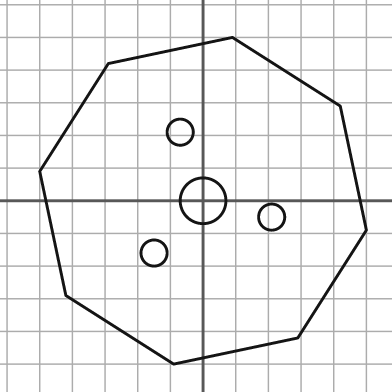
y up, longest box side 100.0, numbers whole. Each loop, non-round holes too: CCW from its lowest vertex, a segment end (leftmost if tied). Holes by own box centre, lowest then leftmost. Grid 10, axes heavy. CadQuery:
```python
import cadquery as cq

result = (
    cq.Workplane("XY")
    .moveTo(-9.0, -50.0)
    .lineTo(29.0, -42.0)
    .lineTo(50.0, -9.0)
    .lineTo(42.0, 29.0)
    .lineTo(9.0, 50.0)
    .lineTo(-29.0, 42.0)
    .lineTo(-50.0, 9.0)
    .lineTo(-42.0, -29.0)
    .close()
    .moveTo(-15.0, -16.0)
    .circle(4.0)
    .moveTo(21.0, -5.0)
    .circle(4.0)
    .moveTo(0.0, 0.0)
    .circle(7.0)
    .moveTo(-7.0, 21.0)
    .circle(4.0)
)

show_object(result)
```